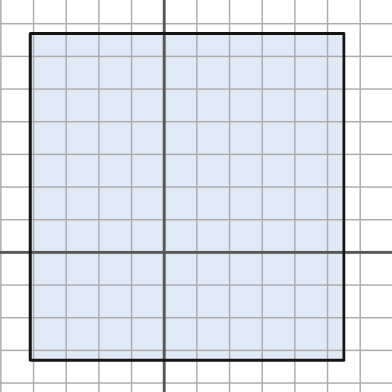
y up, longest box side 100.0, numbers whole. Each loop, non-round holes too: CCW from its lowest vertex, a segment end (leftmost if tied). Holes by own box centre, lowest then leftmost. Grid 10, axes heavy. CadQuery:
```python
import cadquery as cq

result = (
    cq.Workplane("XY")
    .moveTo(-41.0, -33.0)
    .lineTo(55.0, -33.0)
    .lineTo(55.0, 67.0)
    .lineTo(-41.0, 67.0)
    .close()
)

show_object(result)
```